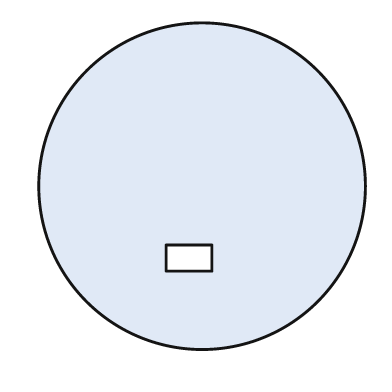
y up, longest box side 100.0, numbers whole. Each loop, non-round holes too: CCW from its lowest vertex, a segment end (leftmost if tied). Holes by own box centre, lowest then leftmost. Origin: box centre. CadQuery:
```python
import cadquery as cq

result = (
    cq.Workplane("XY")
    .moveTo(0.0, 0.0)
    .circle(50.0)
    .moveTo(-11.0, -26.0)
    .lineTo(3.0, -26.0)
    .lineTo(3.0, -18.0)
    .lineTo(-11.0, -18.0)
    .close()
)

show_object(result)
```